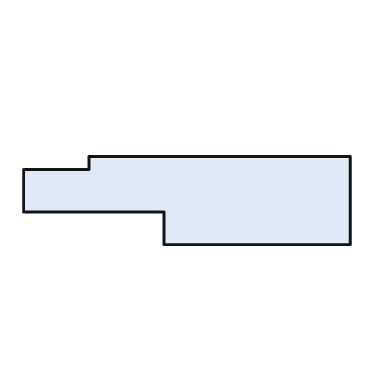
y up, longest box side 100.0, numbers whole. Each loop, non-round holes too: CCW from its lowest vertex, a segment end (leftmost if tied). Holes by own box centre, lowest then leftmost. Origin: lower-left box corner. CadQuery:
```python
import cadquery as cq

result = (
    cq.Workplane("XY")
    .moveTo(43.0, 0.0)
    .lineTo(100.0, 0.0)
    .lineTo(100.0, 27.0)
    .lineTo(20.0, 27.0)
    .lineTo(20.0, 23.0)
    .lineTo(0.0, 23.0)
    .lineTo(0.0, 10.0)
    .lineTo(43.0, 10.0)
    .close()
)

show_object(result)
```